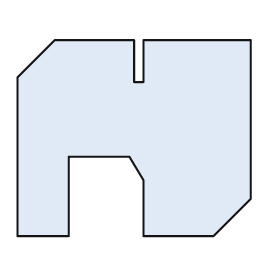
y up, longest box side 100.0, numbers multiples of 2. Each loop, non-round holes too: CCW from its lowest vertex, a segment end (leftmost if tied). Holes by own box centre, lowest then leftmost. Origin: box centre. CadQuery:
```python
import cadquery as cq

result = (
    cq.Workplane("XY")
    .moveTo(-50.0, -42.0)
    .lineTo(-28.0, -42.0)
    .lineTo(-28.0, -8.0)
    .lineTo(-2.0, -8.0)
    .lineTo(4.0, -18.0)
    .lineTo(4.0, -42.0)
    .lineTo(34.0, -42.0)
    .lineTo(50.0, -26.0)
    .lineTo(50.0, 42.0)
    .lineTo(4.0, 42.0)
    .lineTo(4.0, 24.0)
    .lineTo(0.0, 24.0)
    .lineTo(0.0, 42.0)
    .lineTo(-34.0, 42.0)
    .lineTo(-50.0, 26.0)
    .close()
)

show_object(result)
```